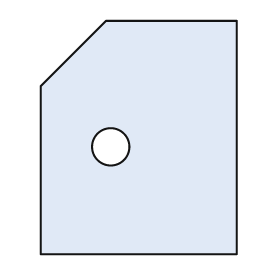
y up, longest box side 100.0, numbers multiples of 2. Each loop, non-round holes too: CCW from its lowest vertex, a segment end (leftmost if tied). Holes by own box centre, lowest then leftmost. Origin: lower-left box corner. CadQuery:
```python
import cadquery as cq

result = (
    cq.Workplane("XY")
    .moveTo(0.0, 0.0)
    .lineTo(84.0, 0.0)
    .lineTo(84.0, 100.0)
    .lineTo(28.0, 100.0)
    .lineTo(0.0, 72.0)
    .close()
    .moveTo(30.0, 46.0)
    .circle(8.0)
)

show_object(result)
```